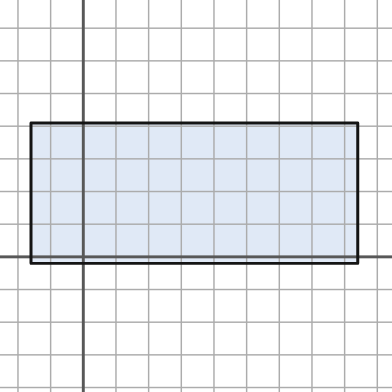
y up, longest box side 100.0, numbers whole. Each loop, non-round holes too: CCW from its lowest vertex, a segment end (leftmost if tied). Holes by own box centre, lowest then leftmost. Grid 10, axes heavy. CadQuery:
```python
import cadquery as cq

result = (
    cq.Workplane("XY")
    .moveTo(-16.0, -2.0)
    .lineTo(84.0, -2.0)
    .lineTo(84.0, 41.0)
    .lineTo(-16.0, 41.0)
    .close()
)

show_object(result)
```